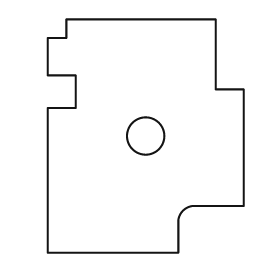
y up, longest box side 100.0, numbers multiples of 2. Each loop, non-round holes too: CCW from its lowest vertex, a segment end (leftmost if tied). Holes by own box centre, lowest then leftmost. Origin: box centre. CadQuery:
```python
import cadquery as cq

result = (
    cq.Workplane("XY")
    .moveTo(-42.0, -50.0)
    .lineTo(14.0, -50.0)
    .lineTo(14.0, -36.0)
    .threePointArc((16.0, -32.0), (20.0, -30.0))
    .lineTo(42.0, -30.0)
    .lineTo(42.0, 20.0)
    .lineTo(30.0, 20.0)
    .lineTo(30.0, 50.0)
    .lineTo(-34.0, 50.0)
    .lineTo(-34.0, 42.0)
    .lineTo(-42.0, 42.0)
    .lineTo(-42.0, 26.0)
    .lineTo(-30.0, 26.0)
    .lineTo(-30.0, 12.0)
    .lineTo(-42.0, 12.0)
    .close()
    .moveTo(0.0, 0.0)
    .circle(8.0)
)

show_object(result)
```